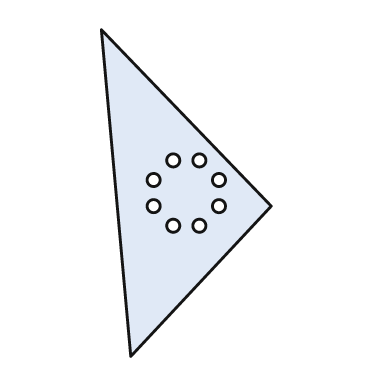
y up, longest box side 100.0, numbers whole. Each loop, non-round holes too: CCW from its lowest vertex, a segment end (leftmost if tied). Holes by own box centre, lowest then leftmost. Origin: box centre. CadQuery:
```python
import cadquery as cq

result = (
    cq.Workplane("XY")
    .moveTo(-17.0, -50.0)
    .lineTo(26.0, -4.0)
    .lineTo(-26.0, 50.0)
    .close()
    .moveTo(-4.0, -10.0)
    .circle(2.0)
    .moveTo(4.0, -10.0)
    .circle(2.0)
    .moveTo(-10.0, -4.0)
    .circle(2.0)
    .moveTo(10.0, -4.0)
    .circle(2.0)
    .moveTo(-10.0, 4.0)
    .circle(2.0)
    .moveTo(10.0, 4.0)
    .circle(2.0)
    .moveTo(-4.0, 10.0)
    .circle(2.0)
    .moveTo(4.0, 10.0)
    .circle(2.0)
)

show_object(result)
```